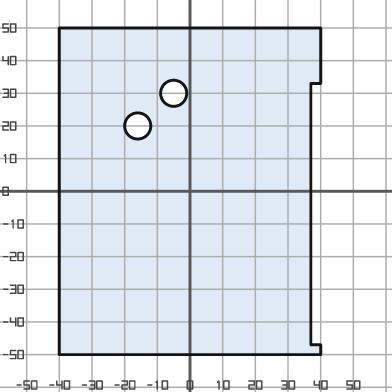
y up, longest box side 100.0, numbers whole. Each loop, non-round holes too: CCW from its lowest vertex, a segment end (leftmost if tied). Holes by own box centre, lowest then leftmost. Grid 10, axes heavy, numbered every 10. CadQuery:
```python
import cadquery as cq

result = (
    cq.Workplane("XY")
    .moveTo(-40.0, -50.0)
    .lineTo(40.0, -50.0)
    .lineTo(40.0, -47.0)
    .lineTo(37.0, -47.0)
    .lineTo(37.0, 33.0)
    .lineTo(40.0, 33.0)
    .lineTo(40.0, 50.0)
    .lineTo(-40.0, 50.0)
    .close()
    .moveTo(-16.0, 20.0)
    .circle(4.0)
    .moveTo(-5.0, 30.0)
    .circle(4.0)
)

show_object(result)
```